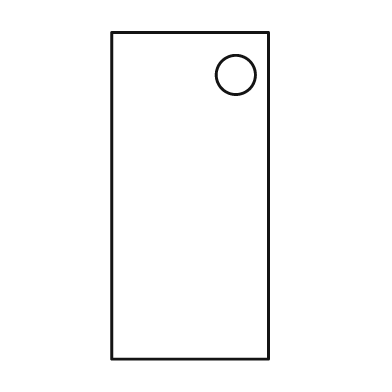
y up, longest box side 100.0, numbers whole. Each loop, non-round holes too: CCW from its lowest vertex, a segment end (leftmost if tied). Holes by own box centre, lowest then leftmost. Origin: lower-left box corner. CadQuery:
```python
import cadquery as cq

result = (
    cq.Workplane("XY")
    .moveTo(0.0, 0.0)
    .lineTo(48.0, 0.0)
    .lineTo(48.0, 100.0)
    .lineTo(0.0, 100.0)
    .close()
    .moveTo(38.0, 87.0)
    .circle(6.0)
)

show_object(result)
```